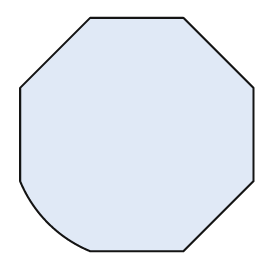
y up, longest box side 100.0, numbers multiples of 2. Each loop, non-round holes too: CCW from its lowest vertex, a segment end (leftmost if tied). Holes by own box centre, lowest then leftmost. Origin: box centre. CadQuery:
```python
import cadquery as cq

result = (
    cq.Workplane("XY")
    .moveTo(-20.0, -50.0)
    .lineTo(20.0, -50.0)
    .lineTo(50.0, -20.0)
    .lineTo(50.0, 20.0)
    .lineTo(20.0, 50.0)
    .lineTo(-20.0, 50.0)
    .lineTo(-50.0, 20.0)
    .lineTo(-50.0, -20.0)
    .threePointArc((-38.0, -38.0), (-20.0, -50.0))
    .close()
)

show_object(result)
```